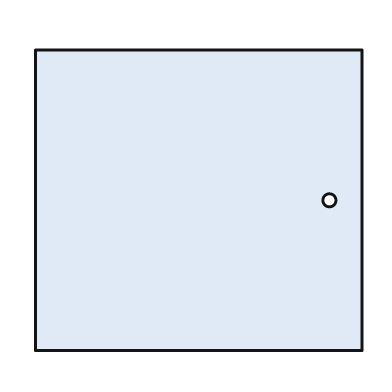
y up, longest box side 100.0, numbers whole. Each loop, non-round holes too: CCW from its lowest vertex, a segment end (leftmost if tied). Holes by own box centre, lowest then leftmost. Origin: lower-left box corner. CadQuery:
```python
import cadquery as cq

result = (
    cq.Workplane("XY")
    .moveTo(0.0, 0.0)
    .lineTo(100.0, 0.0)
    .lineTo(100.0, 92.0)
    .lineTo(0.0, 92.0)
    .close()
    .moveTo(90.0, 46.0)
    .circle(2.0)
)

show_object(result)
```